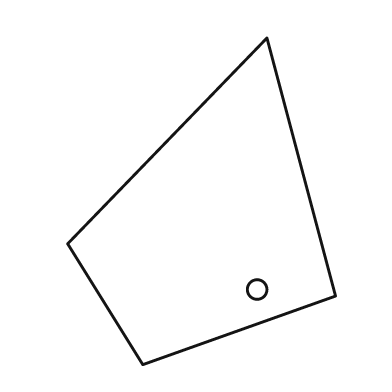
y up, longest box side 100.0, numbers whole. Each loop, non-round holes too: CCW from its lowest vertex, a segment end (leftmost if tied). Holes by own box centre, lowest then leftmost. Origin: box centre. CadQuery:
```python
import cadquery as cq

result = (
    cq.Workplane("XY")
    .moveTo(-18.0, -50.0)
    .lineTo(41.0, -29.0)
    .lineTo(20.0, 50.0)
    .lineTo(-41.0, -13.0)
    .close()
    .moveTo(17.0, -27.0)
    .circle(3.0)
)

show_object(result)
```